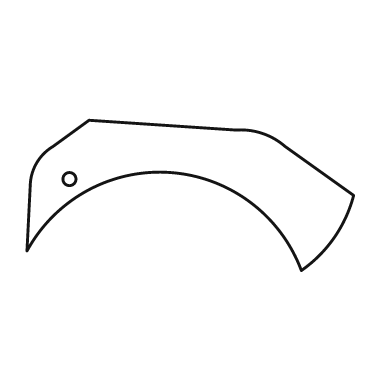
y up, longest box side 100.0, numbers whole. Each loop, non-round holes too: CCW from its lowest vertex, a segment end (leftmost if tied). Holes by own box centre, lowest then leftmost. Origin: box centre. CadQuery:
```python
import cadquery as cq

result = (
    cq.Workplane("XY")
    .moveTo(34.0, -23.0)
    .threePointArc((44.0, -13.0), (50.0, 0.0))
    .lineTo(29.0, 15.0)
    .threePointArc((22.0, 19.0), (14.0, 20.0))
    .lineTo(-31.0, 23.0)
    .lineTo(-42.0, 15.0)
    .threePointArc((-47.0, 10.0), (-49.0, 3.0))
    .lineTo(-50.0, -17.0)
    .threePointArc((-6.0, 7.0), (34.0, -23.0))
    .close()
    .moveTo(-37.0, 5.0)
    .circle(2.0)
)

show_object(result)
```